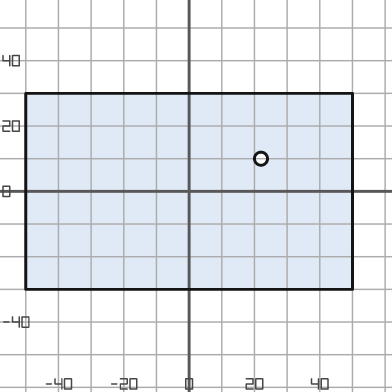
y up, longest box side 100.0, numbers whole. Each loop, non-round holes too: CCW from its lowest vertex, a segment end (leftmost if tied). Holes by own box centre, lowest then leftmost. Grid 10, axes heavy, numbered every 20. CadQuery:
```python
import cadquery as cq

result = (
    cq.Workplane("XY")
    .moveTo(-50.0, -30.0)
    .lineTo(50.0, -30.0)
    .lineTo(50.0, 30.0)
    .lineTo(-50.0, 30.0)
    .close()
    .moveTo(22.0, 10.0)
    .circle(2.0)
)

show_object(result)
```